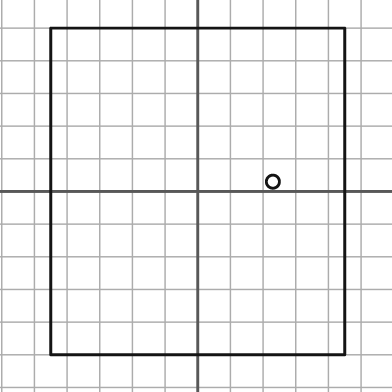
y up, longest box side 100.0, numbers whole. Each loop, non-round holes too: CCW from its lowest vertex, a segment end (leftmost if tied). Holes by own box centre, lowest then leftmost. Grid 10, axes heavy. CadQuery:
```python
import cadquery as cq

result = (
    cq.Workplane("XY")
    .moveTo(-45.0, -50.0)
    .lineTo(45.0, -50.0)
    .lineTo(45.0, 50.0)
    .lineTo(-45.0, 50.0)
    .close()
    .moveTo(23.0, 3.0)
    .circle(2.0)
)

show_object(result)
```